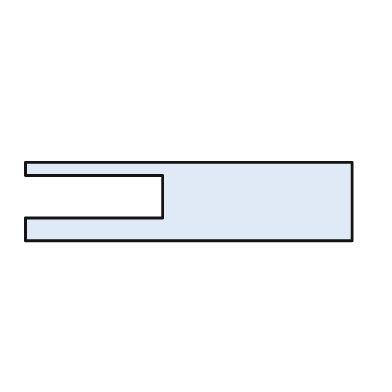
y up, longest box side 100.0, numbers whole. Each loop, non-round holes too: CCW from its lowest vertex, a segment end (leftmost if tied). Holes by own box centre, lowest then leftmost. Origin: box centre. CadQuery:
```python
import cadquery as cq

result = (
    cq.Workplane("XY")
    .moveTo(-50.0, -12.0)
    .lineTo(50.0, -12.0)
    .lineTo(50.0, 12.0)
    .lineTo(-50.0, 12.0)
    .lineTo(-50.0, 8.0)
    .lineTo(-8.0, 8.0)
    .lineTo(-8.0, -5.0)
    .lineTo(-50.0, -5.0)
    .close()
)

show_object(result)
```